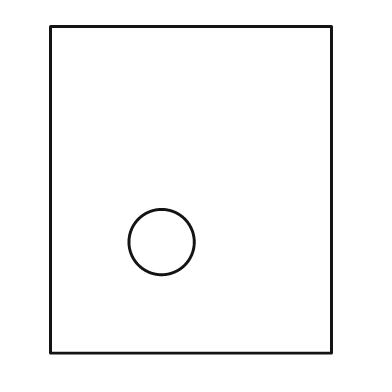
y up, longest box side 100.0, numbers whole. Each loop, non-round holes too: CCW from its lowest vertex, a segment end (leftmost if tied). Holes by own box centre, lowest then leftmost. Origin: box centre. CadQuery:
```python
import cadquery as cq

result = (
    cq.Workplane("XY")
    .moveTo(-43.0, -50.0)
    .lineTo(43.0, -50.0)
    .lineTo(43.0, 50.0)
    .lineTo(-43.0, 50.0)
    .close()
    .moveTo(-9.0, -16.0)
    .circle(10.0)
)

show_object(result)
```